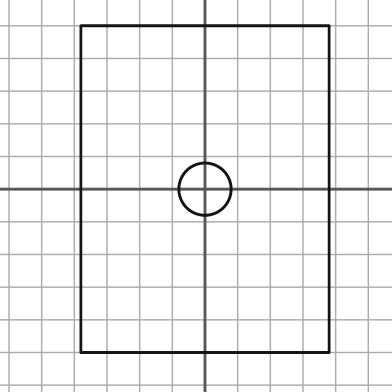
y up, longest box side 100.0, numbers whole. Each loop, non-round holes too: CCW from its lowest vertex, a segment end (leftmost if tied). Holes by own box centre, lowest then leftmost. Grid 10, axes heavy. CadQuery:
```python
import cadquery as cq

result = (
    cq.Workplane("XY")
    .moveTo(-38.0, -50.0)
    .lineTo(38.0, -50.0)
    .lineTo(38.0, 50.0)
    .lineTo(-38.0, 50.0)
    .close()
    .moveTo(0.0, 0.0)
    .circle(8.0)
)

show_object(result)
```